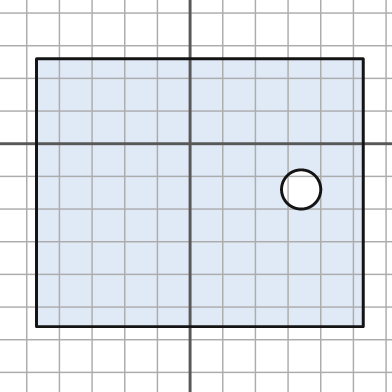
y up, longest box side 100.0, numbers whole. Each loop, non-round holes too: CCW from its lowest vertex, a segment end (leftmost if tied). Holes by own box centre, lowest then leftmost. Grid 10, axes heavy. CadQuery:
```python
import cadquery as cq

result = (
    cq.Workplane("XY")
    .moveTo(-47.0, -56.0)
    .lineTo(53.0, -56.0)
    .lineTo(53.0, 26.0)
    .lineTo(-47.0, 26.0)
    .close()
    .moveTo(34.0, -14.0)
    .circle(6.0)
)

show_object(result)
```